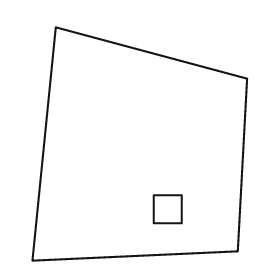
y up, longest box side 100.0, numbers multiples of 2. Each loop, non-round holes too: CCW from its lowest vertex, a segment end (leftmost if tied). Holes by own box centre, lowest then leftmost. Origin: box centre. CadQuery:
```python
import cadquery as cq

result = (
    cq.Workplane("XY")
    .moveTo(-46.0, -50.0)
    .lineTo(42.0, -46.0)
    .lineTo(46.0, 28.0)
    .lineTo(-36.0, 50.0)
    .close()
    .moveTo(6.0, -34.0)
    .lineTo(18.0, -34.0)
    .lineTo(18.0, -22.0)
    .lineTo(6.0, -22.0)
    .close()
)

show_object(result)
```